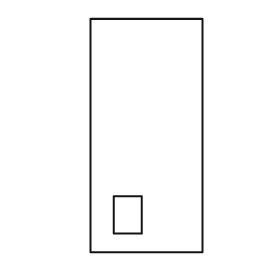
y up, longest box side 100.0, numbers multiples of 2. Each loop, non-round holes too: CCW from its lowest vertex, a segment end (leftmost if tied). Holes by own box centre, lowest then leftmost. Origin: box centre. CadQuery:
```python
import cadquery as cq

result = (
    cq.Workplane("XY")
    .moveTo(-24.0, -50.0)
    .lineTo(24.0, -50.0)
    .lineTo(24.0, 50.0)
    .lineTo(-24.0, 50.0)
    .close()
    .moveTo(-14.0, -42.0)
    .lineTo(-2.0, -42.0)
    .lineTo(-2.0, -26.0)
    .lineTo(-14.0, -26.0)
    .close()
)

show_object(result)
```